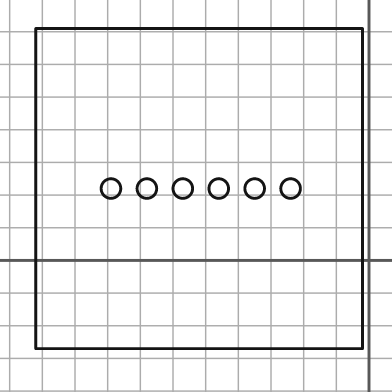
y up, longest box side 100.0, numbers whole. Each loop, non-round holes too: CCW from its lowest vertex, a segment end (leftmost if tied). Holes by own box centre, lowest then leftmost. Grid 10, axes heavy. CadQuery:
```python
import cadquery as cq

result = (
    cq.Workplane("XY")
    .moveTo(-102.0, -27.0)
    .lineTo(-2.0, -27.0)
    .lineTo(-2.0, 71.0)
    .lineTo(-102.0, 71.0)
    .close()
    .moveTo(-79.0, 22.0)
    .circle(3.0)
    .moveTo(-68.0, 22.0)
    .circle(3.0)
    .moveTo(-57.0, 22.0)
    .circle(3.0)
    .moveTo(-46.0, 22.0)
    .circle(3.0)
    .moveTo(-35.0, 22.0)
    .circle(3.0)
    .moveTo(-24.0, 22.0)
    .circle(3.0)
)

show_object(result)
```